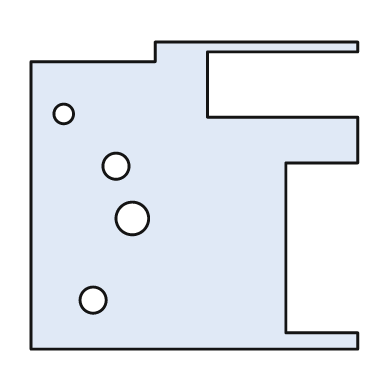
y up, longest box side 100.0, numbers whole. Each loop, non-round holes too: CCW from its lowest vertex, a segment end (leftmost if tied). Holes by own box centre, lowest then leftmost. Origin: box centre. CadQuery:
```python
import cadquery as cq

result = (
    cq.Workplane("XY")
    .moveTo(-50.0, -47.0)
    .lineTo(50.0, -47.0)
    .lineTo(50.0, -42.0)
    .lineTo(28.0, -42.0)
    .lineTo(28.0, 10.0)
    .lineTo(50.0, 10.0)
    .lineTo(50.0, 24.0)
    .lineTo(4.0, 24.0)
    .lineTo(4.0, 44.0)
    .lineTo(50.0, 44.0)
    .lineTo(50.0, 47.0)
    .lineTo(-12.0, 47.0)
    .lineTo(-12.0, 41.0)
    .lineTo(-50.0, 41.0)
    .close()
    .moveTo(-31.0, -32.0)
    .circle(4.0)
    .moveTo(-19.0, -7.0)
    .circle(5.0)
    .moveTo(-24.0, 9.0)
    .circle(4.0)
    .moveTo(-40.0, 25.0)
    .circle(3.0)
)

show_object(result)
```